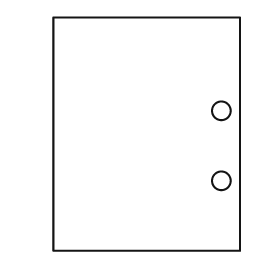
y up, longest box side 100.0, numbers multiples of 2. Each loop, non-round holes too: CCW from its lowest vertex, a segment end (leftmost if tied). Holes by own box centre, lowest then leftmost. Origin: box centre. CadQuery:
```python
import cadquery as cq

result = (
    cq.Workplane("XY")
    .moveTo(-40.0, -50.0)
    .lineTo(40.0, -50.0)
    .lineTo(40.0, 50.0)
    .lineTo(-40.0, 50.0)
    .close()
    .moveTo(32.0, -20.0)
    .circle(4.0)
    .moveTo(32.0, 10.0)
    .circle(4.0)
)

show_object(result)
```